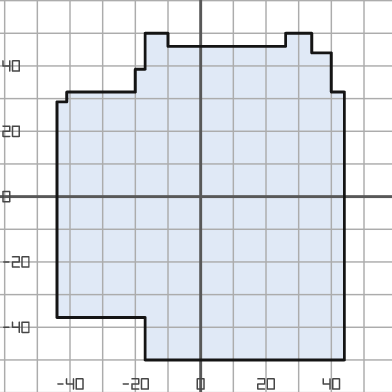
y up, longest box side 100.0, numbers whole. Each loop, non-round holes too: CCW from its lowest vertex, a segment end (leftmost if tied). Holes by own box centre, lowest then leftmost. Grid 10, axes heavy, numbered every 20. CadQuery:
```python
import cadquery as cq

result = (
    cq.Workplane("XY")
    .moveTo(-17.0, -50.0)
    .lineTo(44.0, -50.0)
    .lineTo(44.0, 32.0)
    .lineTo(40.0, 32.0)
    .lineTo(40.0, 44.0)
    .lineTo(34.0, 44.0)
    .lineTo(34.0, 50.0)
    .lineTo(26.0, 50.0)
    .lineTo(26.0, 46.0)
    .lineTo(-10.0, 46.0)
    .lineTo(-10.0, 50.0)
    .lineTo(-17.0, 50.0)
    .lineTo(-17.0, 39.0)
    .lineTo(-20.0, 39.0)
    .lineTo(-20.0, 32.0)
    .lineTo(-41.0, 32.0)
    .lineTo(-41.0, 29.0)
    .lineTo(-44.0, 29.0)
    .lineTo(-44.0, -37.0)
    .lineTo(-17.0, -37.0)
    .close()
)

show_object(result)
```